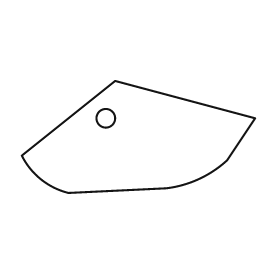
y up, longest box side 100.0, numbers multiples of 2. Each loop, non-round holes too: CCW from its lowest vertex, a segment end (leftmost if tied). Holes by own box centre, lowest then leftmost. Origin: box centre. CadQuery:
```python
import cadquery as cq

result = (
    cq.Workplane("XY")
    .moveTo(-30.0, -24.0)
    .lineTo(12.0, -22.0)
    .threePointArc((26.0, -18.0), (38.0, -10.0))
    .lineTo(50.0, 8.0)
    .lineTo(-10.0, 24.0)
    .lineTo(-50.0, -8.0)
    .threePointArc((-42.0, -18.0), (-30.0, -24.0))
    .close()
    .moveTo(-14.0, 8.0)
    .circle(4.0)
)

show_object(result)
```